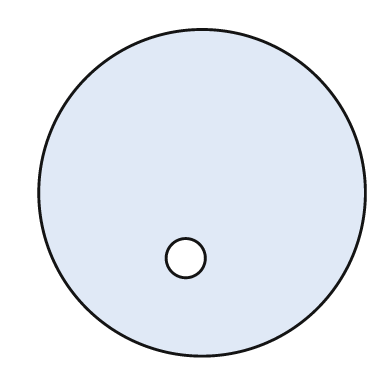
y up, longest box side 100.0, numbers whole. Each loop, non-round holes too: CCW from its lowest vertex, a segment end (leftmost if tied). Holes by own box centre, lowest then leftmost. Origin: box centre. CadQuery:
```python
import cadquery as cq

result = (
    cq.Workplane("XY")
    .moveTo(0.0, 0.0)
    .circle(50.0)
    .moveTo(-5.0, -20.0)
    .circle(6.0)
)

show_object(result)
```